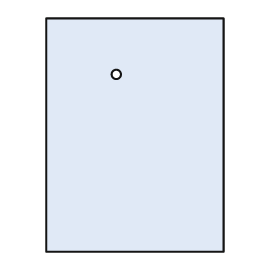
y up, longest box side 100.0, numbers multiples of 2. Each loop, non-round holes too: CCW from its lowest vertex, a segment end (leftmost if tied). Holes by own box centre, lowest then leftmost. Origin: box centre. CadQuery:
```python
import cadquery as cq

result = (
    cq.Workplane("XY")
    .moveTo(-38.0, -50.0)
    .lineTo(38.0, -50.0)
    .lineTo(38.0, 50.0)
    .lineTo(-38.0, 50.0)
    .close()
    .moveTo(-8.0, 26.0)
    .circle(2.0)
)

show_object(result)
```